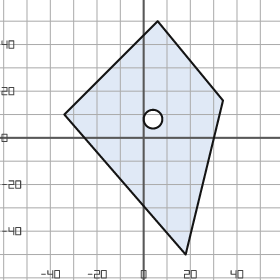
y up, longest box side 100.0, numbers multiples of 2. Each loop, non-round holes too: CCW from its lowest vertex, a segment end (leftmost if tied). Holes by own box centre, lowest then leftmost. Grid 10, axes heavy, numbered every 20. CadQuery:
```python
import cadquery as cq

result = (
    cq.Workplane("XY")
    .moveTo(18.0, -50.0)
    .lineTo(34.0, 16.0)
    .lineTo(6.0, 50.0)
    .lineTo(-34.0, 10.0)
    .close()
    .moveTo(4.0, 8.0)
    .circle(4.0)
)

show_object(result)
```